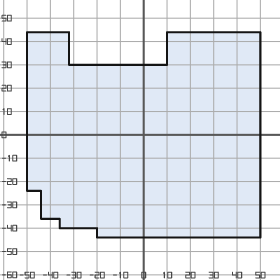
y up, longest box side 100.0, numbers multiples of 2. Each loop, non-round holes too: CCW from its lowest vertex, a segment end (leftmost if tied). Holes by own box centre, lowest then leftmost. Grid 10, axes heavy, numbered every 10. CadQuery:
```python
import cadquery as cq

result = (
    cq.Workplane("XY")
    .moveTo(-20.0, -44.0)
    .lineTo(50.0, -44.0)
    .lineTo(50.0, 44.0)
    .lineTo(10.0, 44.0)
    .lineTo(10.0, 30.0)
    .lineTo(-32.0, 30.0)
    .lineTo(-32.0, 44.0)
    .lineTo(-50.0, 44.0)
    .lineTo(-50.0, -24.0)
    .lineTo(-44.0, -24.0)
    .lineTo(-44.0, -36.0)
    .lineTo(-36.0, -36.0)
    .lineTo(-36.0, -40.0)
    .lineTo(-20.0, -40.0)
    .close()
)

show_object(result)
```